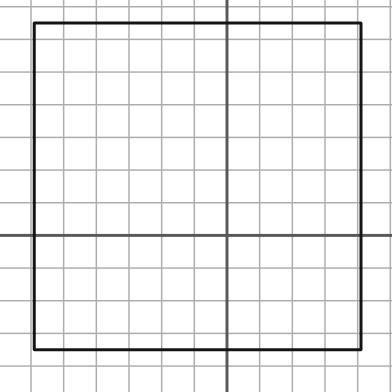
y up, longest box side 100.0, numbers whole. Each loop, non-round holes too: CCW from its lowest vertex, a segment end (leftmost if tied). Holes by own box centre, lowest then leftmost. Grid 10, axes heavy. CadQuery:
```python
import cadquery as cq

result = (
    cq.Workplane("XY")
    .moveTo(-59.0, -35.0)
    .lineTo(41.0, -35.0)
    .lineTo(41.0, 65.0)
    .lineTo(-59.0, 65.0)
    .close()
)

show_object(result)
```